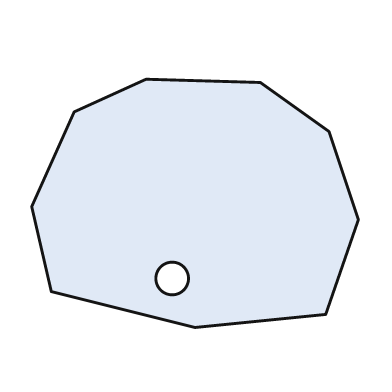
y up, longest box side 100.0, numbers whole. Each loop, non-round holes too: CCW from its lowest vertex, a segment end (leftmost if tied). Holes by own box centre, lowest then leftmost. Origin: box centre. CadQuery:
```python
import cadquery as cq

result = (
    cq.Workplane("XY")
    .moveTo(0.0, -38.0)
    .lineTo(40.0, -34.0)
    .lineTo(50.0, -5.0)
    .lineTo(41.0, 22.0)
    .lineTo(20.0, 37.0)
    .lineTo(-15.0, 38.0)
    .lineTo(-37.0, 28.0)
    .lineTo(-50.0, -1.0)
    .lineTo(-44.0, -27.0)
    .close()
    .moveTo(-7.0, -23.0)
    .circle(5.0)
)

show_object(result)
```